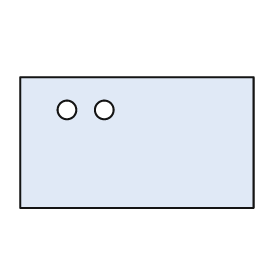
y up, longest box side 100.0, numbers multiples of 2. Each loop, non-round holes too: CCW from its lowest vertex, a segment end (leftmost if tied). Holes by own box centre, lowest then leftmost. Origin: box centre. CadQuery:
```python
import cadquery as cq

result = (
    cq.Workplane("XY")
    .moveTo(-50.0, -28.0)
    .lineTo(50.0, -28.0)
    .lineTo(50.0, 28.0)
    .lineTo(-50.0, 28.0)
    .close()
    .moveTo(-30.0, 14.0)
    .circle(4.0)
    .moveTo(-14.0, 14.0)
    .circle(4.0)
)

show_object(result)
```